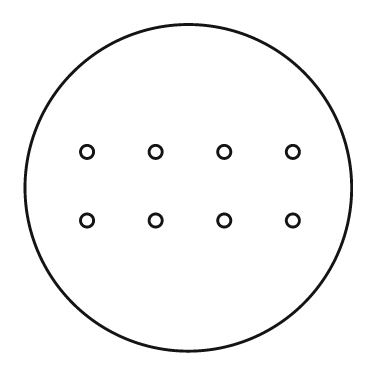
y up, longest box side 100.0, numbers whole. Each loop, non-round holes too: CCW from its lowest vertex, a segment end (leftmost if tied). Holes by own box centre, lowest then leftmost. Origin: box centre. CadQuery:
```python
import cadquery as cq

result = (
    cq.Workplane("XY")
    .moveTo(0.0, 0.0)
    .circle(50.0)
    .moveTo(-31.0, -10.0)
    .circle(2.0)
    .moveTo(-10.0, -10.0)
    .circle(2.0)
    .moveTo(11.0, -10.0)
    .circle(2.0)
    .moveTo(32.0, -10.0)
    .circle(2.0)
    .moveTo(-31.0, 11.0)
    .circle(2.0)
    .moveTo(-10.0, 11.0)
    .circle(2.0)
    .moveTo(11.0, 11.0)
    .circle(2.0)
    .moveTo(32.0, 11.0)
    .circle(2.0)
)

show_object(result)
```